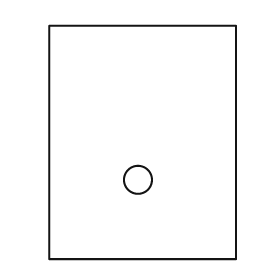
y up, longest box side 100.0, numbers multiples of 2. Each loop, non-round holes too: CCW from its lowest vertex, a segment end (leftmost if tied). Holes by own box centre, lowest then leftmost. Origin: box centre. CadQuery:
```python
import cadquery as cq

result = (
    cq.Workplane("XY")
    .moveTo(-40.0, -50.0)
    .lineTo(40.0, -50.0)
    .lineTo(40.0, 50.0)
    .lineTo(-40.0, 50.0)
    .close()
    .moveTo(-2.0, -16.0)
    .circle(6.0)
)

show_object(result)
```